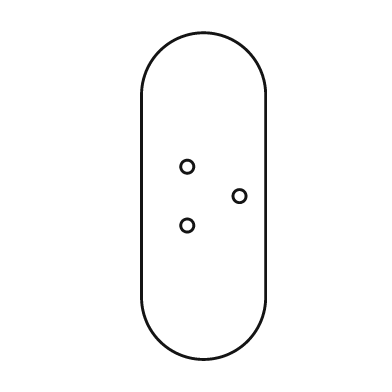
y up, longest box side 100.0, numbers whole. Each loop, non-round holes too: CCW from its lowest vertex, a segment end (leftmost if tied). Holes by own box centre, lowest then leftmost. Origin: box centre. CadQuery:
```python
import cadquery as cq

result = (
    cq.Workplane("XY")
    .moveTo(-19.0, -31.0)
    .threePointArc((0.0, -50.0), (19.0, -31.0))
    .lineTo(19.0, 31.0)
    .threePointArc((0.0, 50.0), (-19.0, 31.0))
    .close()
    .moveTo(-5.0, -9.0)
    .circle(2.0)
    .moveTo(11.0, 0.0)
    .circle(2.0)
    .moveTo(-5.0, 9.0)
    .circle(2.0)
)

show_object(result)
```